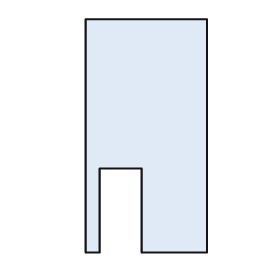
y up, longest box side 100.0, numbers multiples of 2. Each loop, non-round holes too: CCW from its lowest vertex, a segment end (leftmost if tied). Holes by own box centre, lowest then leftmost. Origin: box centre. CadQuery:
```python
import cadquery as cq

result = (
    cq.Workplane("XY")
    .moveTo(-26.0, -50.0)
    .lineTo(-20.0, -50.0)
    .lineTo(-20.0, -14.0)
    .lineTo(-2.0, -14.0)
    .lineTo(-2.0, -50.0)
    .lineTo(26.0, -50.0)
    .lineTo(26.0, 50.0)
    .lineTo(-26.0, 50.0)
    .close()
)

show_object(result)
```